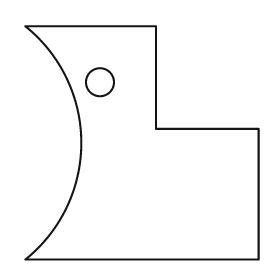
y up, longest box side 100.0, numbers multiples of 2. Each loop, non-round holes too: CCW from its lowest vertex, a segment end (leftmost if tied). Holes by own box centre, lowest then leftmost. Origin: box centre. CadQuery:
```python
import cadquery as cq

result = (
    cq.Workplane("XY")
    .moveTo(-50.0, -50.0)
    .lineTo(50.0, -50.0)
    .lineTo(50.0, 6.0)
    .lineTo(6.0, 6.0)
    .lineTo(6.0, 50.0)
    .lineTo(-50.0, 50.0)
    .threePointArc((-26.0, 0.0), (-50.0, -50.0))
    .close()
    .moveTo(-18.0, 26.0)
    .circle(6.0)
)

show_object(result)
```